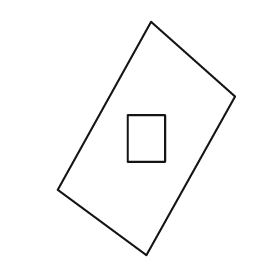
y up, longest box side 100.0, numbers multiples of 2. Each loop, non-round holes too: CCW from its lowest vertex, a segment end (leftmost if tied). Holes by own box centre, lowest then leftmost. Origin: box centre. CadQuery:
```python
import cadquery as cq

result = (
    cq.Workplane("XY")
    .moveTo(0.0, -50.0)
    .lineTo(38.0, 18.0)
    .lineTo(2.0, 50.0)
    .lineTo(-38.0, -22.0)
    .close()
    .moveTo(-8.0, -10.0)
    .lineTo(8.0, -10.0)
    .lineTo(8.0, 10.0)
    .lineTo(-8.0, 10.0)
    .close()
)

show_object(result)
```